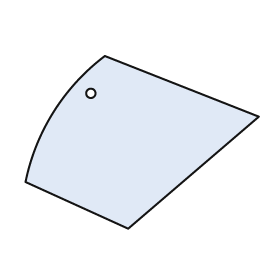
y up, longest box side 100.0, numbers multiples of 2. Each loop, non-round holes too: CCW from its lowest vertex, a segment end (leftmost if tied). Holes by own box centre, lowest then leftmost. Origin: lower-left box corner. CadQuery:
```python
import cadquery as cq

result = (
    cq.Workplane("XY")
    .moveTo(44.0, 0.0)
    .lineTo(100.0, 48.0)
    .lineTo(34.0, 74.0)
    .threePointArc((12.0, 50.0), (0.0, 20.0))
    .close()
    .moveTo(28.0, 58.0)
    .circle(2.0)
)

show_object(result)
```